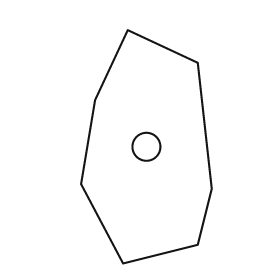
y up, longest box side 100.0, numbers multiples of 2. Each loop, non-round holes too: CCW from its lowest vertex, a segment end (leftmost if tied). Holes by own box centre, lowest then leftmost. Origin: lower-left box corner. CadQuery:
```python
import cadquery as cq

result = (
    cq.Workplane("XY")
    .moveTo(18.0, 0.0)
    .lineTo(50.0, 8.0)
    .lineTo(56.0, 32.0)
    .lineTo(50.0, 86.0)
    .lineTo(20.0, 100.0)
    .lineTo(6.0, 70.0)
    .lineTo(0.0, 34.0)
    .close()
    .moveTo(28.0, 50.0)
    .circle(6.0)
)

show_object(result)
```